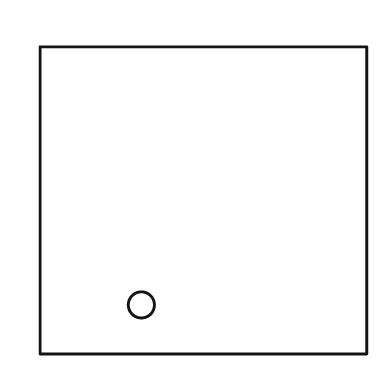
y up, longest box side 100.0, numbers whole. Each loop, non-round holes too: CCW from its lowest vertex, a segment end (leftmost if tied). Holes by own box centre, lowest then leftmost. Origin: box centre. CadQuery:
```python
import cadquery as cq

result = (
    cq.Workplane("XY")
    .moveTo(-50.0, -47.0)
    .lineTo(50.0, -47.0)
    .lineTo(50.0, 47.0)
    .lineTo(-50.0, 47.0)
    .close()
    .moveTo(-19.0, -32.0)
    .circle(4.0)
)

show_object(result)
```